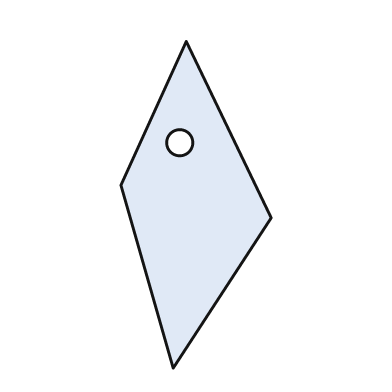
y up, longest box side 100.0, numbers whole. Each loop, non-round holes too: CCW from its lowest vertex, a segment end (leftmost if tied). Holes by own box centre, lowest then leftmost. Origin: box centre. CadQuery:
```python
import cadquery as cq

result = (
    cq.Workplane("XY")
    .moveTo(-7.0, -50.0)
    .lineTo(23.0, -4.0)
    .lineTo(-3.0, 50.0)
    .lineTo(-23.0, 6.0)
    .close()
    .moveTo(-5.0, 19.0)
    .circle(4.0)
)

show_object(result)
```